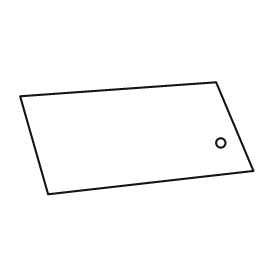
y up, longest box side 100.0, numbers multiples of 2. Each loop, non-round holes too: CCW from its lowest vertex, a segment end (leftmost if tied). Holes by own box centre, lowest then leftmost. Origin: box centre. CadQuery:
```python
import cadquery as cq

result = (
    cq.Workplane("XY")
    .moveTo(-38.0, -24.0)
    .lineTo(50.0, -14.0)
    .lineTo(34.0, 24.0)
    .lineTo(-50.0, 18.0)
    .close()
    .moveTo(36.0, -2.0)
    .circle(2.0)
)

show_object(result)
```